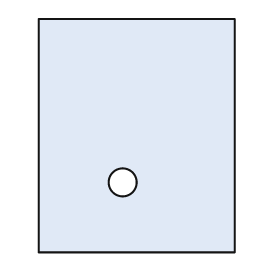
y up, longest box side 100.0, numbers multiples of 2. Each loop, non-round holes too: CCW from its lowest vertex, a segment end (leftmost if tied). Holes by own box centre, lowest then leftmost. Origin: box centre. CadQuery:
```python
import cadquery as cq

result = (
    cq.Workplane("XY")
    .moveTo(-42.0, -50.0)
    .lineTo(42.0, -50.0)
    .lineTo(42.0, 50.0)
    .lineTo(-42.0, 50.0)
    .close()
    .moveTo(-6.0, -20.0)
    .circle(6.0)
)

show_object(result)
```